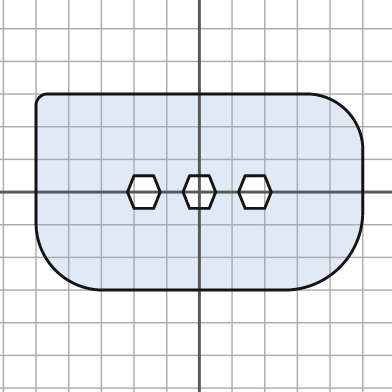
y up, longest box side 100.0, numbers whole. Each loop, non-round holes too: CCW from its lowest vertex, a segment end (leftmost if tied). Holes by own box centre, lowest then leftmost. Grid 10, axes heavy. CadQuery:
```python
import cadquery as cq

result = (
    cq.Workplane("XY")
    .moveTo(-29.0, -30.0)
    .lineTo(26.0, -30.0)
    .threePointArc((43.0, -23.0), (50.0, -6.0))
    .lineTo(50.0, 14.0)
    .threePointArc((45.0, 25.0), (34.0, 30.0))
    .lineTo(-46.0, 30.0)
    .threePointArc((-49.0, 29.0), (-50.0, 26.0))
    .lineTo(-50.0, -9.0)
    .threePointArc((-44.0, -24.0), (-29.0, -30.0))
    .close()
    .moveTo(-20.0, -5.0)
    .lineTo(-14.0, -5.0)
    .lineTo(-12.0, 0.0)
    .lineTo(-14.0, 5.0)
    .lineTo(-20.0, 5.0)
    .lineTo(-22.0, 0.0)
    .close()
    .moveTo(-3.0, -5.0)
    .lineTo(3.0, -5.0)
    .lineTo(5.0, 0.0)
    .lineTo(3.0, 5.0)
    .lineTo(-3.0, 5.0)
    .lineTo(-5.0, 0.0)
    .close()
    .moveTo(14.0, -5.0)
    .lineTo(20.0, -5.0)
    .lineTo(22.0, 0.0)
    .lineTo(20.0, 5.0)
    .lineTo(14.0, 5.0)
    .lineTo(12.0, 0.0)
    .close()
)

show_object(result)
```